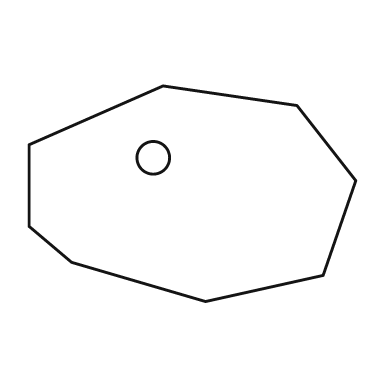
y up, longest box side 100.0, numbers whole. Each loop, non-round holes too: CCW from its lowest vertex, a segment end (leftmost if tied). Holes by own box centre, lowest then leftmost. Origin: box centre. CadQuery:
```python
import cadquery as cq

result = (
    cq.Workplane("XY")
    .moveTo(4.0, -33.0)
    .lineTo(40.0, -25.0)
    .lineTo(50.0, 4.0)
    .lineTo(32.0, 27.0)
    .lineTo(-9.0, 33.0)
    .lineTo(-50.0, 15.0)
    .lineTo(-50.0, -10.0)
    .lineTo(-37.0, -21.0)
    .close()
    .moveTo(-12.0, 11.0)
    .circle(5.0)
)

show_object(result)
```